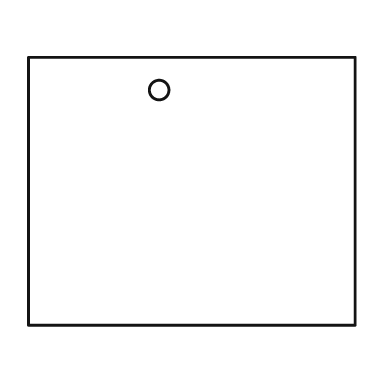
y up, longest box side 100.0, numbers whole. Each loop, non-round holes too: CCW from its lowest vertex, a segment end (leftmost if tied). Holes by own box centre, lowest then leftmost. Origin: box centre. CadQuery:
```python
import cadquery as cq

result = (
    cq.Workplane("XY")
    .moveTo(-50.0, -41.0)
    .lineTo(50.0, -41.0)
    .lineTo(50.0, 41.0)
    .lineTo(-50.0, 41.0)
    .close()
    .moveTo(-10.0, 31.0)
    .circle(3.0)
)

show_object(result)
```